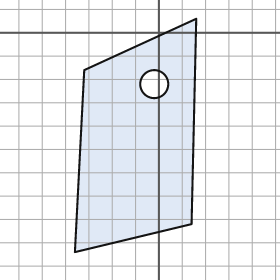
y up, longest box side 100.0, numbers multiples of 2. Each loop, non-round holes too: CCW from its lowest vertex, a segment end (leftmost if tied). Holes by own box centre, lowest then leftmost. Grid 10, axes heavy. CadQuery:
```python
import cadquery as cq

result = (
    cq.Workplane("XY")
    .moveTo(-36.0, -94.0)
    .lineTo(14.0, -82.0)
    .lineTo(16.0, 6.0)
    .lineTo(-32.0, -16.0)
    .close()
    .moveTo(-2.0, -22.0)
    .circle(6.0)
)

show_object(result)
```